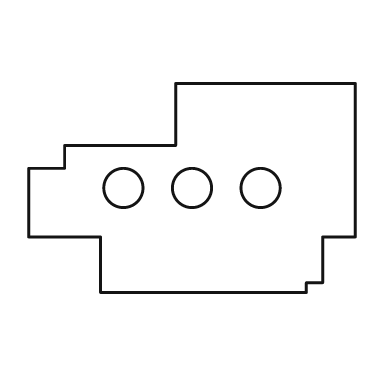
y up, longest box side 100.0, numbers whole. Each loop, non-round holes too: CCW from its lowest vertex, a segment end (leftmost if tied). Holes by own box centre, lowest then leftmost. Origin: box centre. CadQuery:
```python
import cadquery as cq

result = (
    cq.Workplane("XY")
    .moveTo(-28.0, -32.0)
    .lineTo(35.0, -32.0)
    .lineTo(35.0, -29.0)
    .lineTo(40.0, -29.0)
    .lineTo(40.0, -15.0)
    .lineTo(50.0, -15.0)
    .lineTo(50.0, 32.0)
    .lineTo(-5.0, 32.0)
    .lineTo(-5.0, 13.0)
    .lineTo(-39.0, 13.0)
    .lineTo(-39.0, 6.0)
    .lineTo(-50.0, 6.0)
    .lineTo(-50.0, -15.0)
    .lineTo(-28.0, -15.0)
    .close()
    .moveTo(-21.0, 0.0)
    .circle(6.0)
    .moveTo(0.0, 0.0)
    .circle(6.0)
    .moveTo(21.0, 0.0)
    .circle(6.0)
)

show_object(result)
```